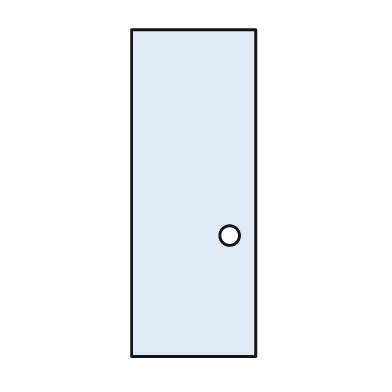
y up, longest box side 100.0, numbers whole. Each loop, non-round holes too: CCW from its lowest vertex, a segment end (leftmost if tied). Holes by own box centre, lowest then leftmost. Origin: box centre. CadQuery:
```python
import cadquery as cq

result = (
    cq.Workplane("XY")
    .moveTo(-19.0, -50.0)
    .lineTo(19.0, -50.0)
    .lineTo(19.0, 50.0)
    .lineTo(-19.0, 50.0)
    .close()
    .moveTo(11.0, -13.0)
    .circle(3.0)
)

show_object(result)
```